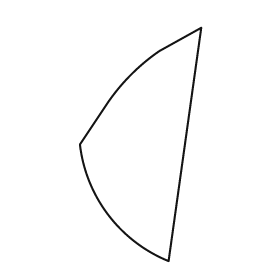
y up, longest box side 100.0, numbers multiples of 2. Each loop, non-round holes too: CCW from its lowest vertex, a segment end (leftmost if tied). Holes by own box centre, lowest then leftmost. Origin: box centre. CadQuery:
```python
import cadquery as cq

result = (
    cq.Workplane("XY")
    .moveTo(12.0, -50.0)
    .lineTo(26.0, 50.0)
    .lineTo(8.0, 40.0)
    .threePointArc((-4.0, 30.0), (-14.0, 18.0))
    .lineTo(-26.0, 0.0)
    .threePointArc((-14.0, -30.0), (12.0, -50.0))
    .close()
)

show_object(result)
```